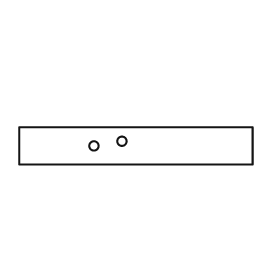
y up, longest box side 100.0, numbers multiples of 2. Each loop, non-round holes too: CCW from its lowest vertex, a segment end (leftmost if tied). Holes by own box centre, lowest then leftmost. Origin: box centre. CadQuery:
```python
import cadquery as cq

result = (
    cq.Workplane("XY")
    .moveTo(-50.0, -8.0)
    .lineTo(50.0, -8.0)
    .lineTo(50.0, 8.0)
    .lineTo(-50.0, 8.0)
    .close()
    .moveTo(-18.0, 0.0)
    .circle(2.0)
    .moveTo(-6.0, 2.0)
    .circle(2.0)
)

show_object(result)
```